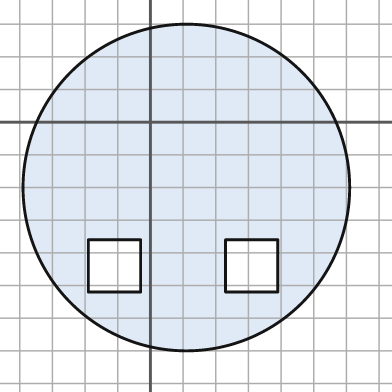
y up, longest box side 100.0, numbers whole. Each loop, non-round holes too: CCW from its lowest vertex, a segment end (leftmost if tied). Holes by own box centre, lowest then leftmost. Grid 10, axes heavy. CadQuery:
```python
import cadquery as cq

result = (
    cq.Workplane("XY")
    .moveTo(11.0, -20.0)
    .circle(50.0)
    .moveTo(-19.0, -52.0)
    .lineTo(-3.0, -52.0)
    .lineTo(-3.0, -36.0)
    .lineTo(-19.0, -36.0)
    .close()
    .moveTo(23.0, -52.0)
    .lineTo(39.0, -52.0)
    .lineTo(39.0, -36.0)
    .lineTo(23.0, -36.0)
    .close()
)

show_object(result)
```